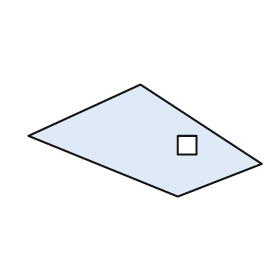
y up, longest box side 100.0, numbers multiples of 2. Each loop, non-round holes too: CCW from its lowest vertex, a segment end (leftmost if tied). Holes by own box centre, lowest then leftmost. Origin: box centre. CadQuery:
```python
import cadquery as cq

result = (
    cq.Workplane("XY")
    .moveTo(14.0, -24.0)
    .lineTo(50.0, -10.0)
    .lineTo(-2.0, 24.0)
    .lineTo(-50.0, 2.0)
    .close()
    .moveTo(14.0, -6.0)
    .lineTo(22.0, -6.0)
    .lineTo(22.0, 2.0)
    .lineTo(14.0, 2.0)
    .close()
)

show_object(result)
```